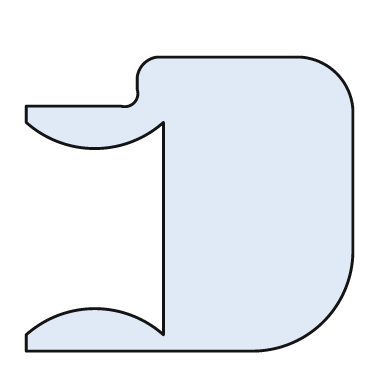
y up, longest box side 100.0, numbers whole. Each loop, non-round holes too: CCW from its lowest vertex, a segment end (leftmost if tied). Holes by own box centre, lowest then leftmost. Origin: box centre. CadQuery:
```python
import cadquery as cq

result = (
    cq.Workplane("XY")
    .moveTo(-50.0, -45.0)
    .lineTo(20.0, -45.0)
    .threePointArc((41.0, -36.0), (50.0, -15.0))
    .lineTo(50.0, 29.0)
    .threePointArc((45.0, 40.0), (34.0, 45.0))
    .lineTo(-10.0, 45.0)
    .threePointArc((-14.0, 43.0), (-16.0, 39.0))
    .lineTo(-16.0, 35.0)
    .threePointArc((-17.0, 31.0), (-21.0, 30.0))
    .lineTo(-50.0, 30.0)
    .lineTo(-50.0, 25.0)
    .threePointArc((-29.0, 17.0), (-8.0, 25.0))
    .lineTo(-8.0, -40.0)
    .threePointArc((-29.0, -32.0), (-50.0, -40.0))
    .close()
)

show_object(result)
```